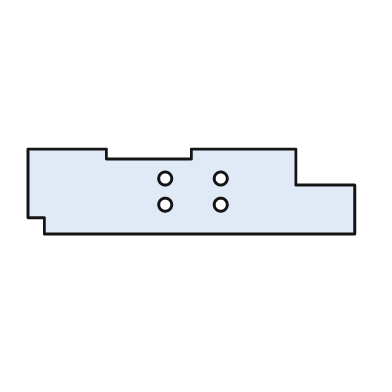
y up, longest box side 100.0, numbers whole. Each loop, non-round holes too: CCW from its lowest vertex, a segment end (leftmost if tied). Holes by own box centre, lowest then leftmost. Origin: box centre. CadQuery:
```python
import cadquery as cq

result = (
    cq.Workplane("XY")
    .moveTo(-45.0, -13.0)
    .lineTo(50.0, -13.0)
    .lineTo(50.0, 2.0)
    .lineTo(32.0, 2.0)
    .lineTo(32.0, 13.0)
    .lineTo(0.0, 13.0)
    .lineTo(0.0, 10.0)
    .lineTo(-26.0, 10.0)
    .lineTo(-26.0, 13.0)
    .lineTo(-50.0, 13.0)
    .lineTo(-50.0, -8.0)
    .lineTo(-45.0, -8.0)
    .close()
    .moveTo(-8.0, -4.0)
    .circle(2.0)
    .moveTo(9.0, -4.0)
    .circle(2.0)
    .moveTo(-8.0, 4.0)
    .circle(2.0)
    .moveTo(9.0, 4.0)
    .circle(2.0)
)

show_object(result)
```